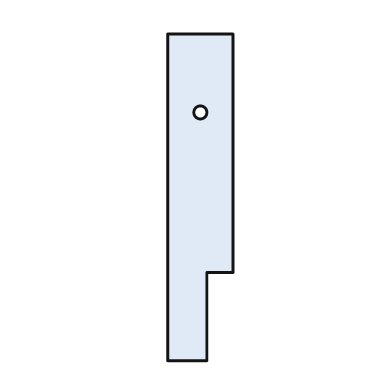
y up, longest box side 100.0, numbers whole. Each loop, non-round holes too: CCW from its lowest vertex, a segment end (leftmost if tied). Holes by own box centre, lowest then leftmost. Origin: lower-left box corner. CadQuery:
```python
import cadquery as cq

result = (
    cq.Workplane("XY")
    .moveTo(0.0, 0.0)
    .lineTo(12.0, 0.0)
    .lineTo(12.0, 27.0)
    .lineTo(20.0, 27.0)
    .lineTo(20.0, 100.0)
    .lineTo(0.0, 100.0)
    .close()
    .moveTo(10.0, 76.0)
    .circle(2.0)
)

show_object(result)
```